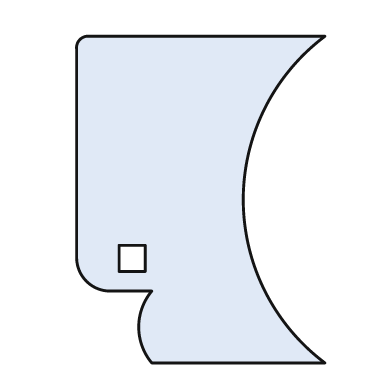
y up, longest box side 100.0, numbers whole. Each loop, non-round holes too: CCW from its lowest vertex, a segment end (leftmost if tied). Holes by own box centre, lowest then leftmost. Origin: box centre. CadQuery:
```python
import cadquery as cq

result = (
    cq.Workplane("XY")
    .moveTo(-15.0, -50.0)
    .lineTo(38.0, -50.0)
    .threePointArc((13.0, 0.0), (38.0, 50.0))
    .lineTo(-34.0, 50.0)
    .threePointArc((-37.0, 49.0), (-38.0, 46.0))
    .lineTo(-38.0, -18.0)
    .threePointArc((-35.0, -25.0), (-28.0, -28.0))
    .lineTo(-15.0, -28.0)
    .threePointArc((-19.0, -39.0), (-15.0, -50.0))
    .close()
    .moveTo(-25.0, -22.0)
    .lineTo(-17.0, -22.0)
    .lineTo(-17.0, -14.0)
    .lineTo(-25.0, -14.0)
    .close()
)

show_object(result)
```